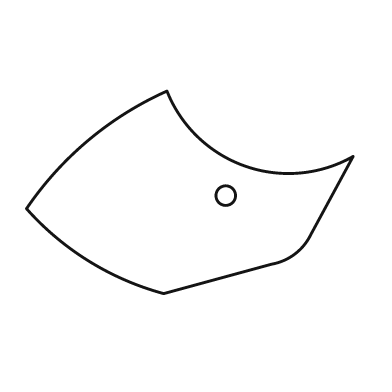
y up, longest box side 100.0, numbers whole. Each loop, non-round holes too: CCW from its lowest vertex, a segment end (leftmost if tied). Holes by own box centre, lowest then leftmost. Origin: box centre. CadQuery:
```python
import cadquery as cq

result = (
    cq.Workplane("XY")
    .moveTo(-8.0, -31.0)
    .lineTo(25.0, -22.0)
    .threePointArc((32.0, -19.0), (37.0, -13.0))
    .lineTo(50.0, 11.0)
    .threePointArc((17.0, 8.0), (-7.0, 31.0))
    .threePointArc((-31.0, 16.0), (-50.0, -5.0))
    .threePointArc((-31.0, -21.0), (-8.0, -31.0))
    .close()
    .moveTo(11.0, -1.0)
    .circle(3.0)
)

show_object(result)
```